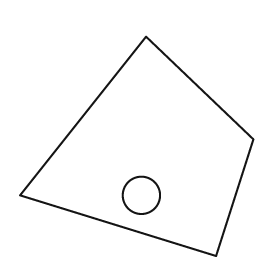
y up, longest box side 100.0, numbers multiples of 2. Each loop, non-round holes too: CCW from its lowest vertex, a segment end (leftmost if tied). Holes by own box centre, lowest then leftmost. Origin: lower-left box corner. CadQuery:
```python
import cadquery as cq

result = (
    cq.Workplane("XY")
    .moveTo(84.0, 0.0)
    .lineTo(100.0, 50.0)
    .lineTo(54.0, 94.0)
    .lineTo(0.0, 26.0)
    .close()
    .moveTo(52.0, 26.0)
    .circle(8.0)
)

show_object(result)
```